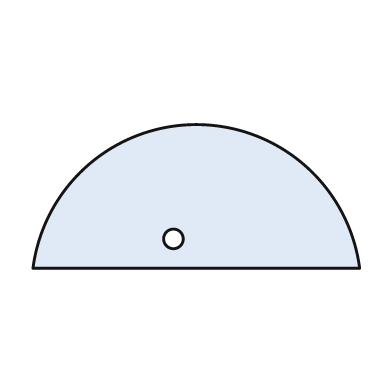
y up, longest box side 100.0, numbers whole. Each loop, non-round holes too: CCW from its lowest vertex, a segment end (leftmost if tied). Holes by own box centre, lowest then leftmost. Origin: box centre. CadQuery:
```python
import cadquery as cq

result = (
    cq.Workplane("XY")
    .moveTo(-50.0, -22.0)
    .lineTo(50.0, -22.0)
    .threePointArc((0.0, 22.0), (-50.0, -22.0))
    .close()
    .moveTo(-7.0, -13.0)
    .circle(3.0)
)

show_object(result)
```